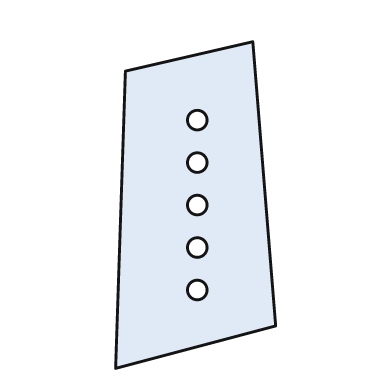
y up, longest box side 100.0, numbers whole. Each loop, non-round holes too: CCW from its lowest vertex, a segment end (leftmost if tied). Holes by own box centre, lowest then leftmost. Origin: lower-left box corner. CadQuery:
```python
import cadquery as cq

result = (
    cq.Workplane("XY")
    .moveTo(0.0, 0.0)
    .lineTo(49.0, 13.0)
    .lineTo(42.0, 100.0)
    .lineTo(3.0, 91.0)
    .close()
    .moveTo(25.0, 24.0)
    .circle(3.0)
    .moveTo(25.0, 37.0)
    .circle(3.0)
    .moveTo(25.0, 50.0)
    .circle(3.0)
    .moveTo(25.0, 63.0)
    .circle(3.0)
    .moveTo(25.0, 76.0)
    .circle(3.0)
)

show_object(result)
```